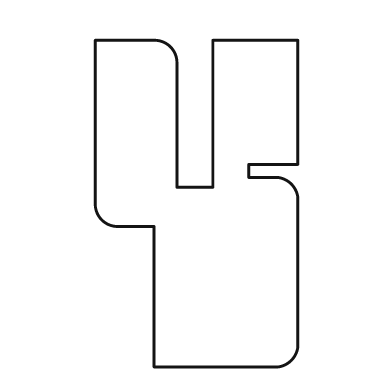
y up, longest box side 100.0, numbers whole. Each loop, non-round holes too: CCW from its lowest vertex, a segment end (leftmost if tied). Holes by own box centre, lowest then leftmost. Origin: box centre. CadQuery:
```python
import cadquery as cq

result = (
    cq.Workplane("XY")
    .moveTo(-13.0, -50.0)
    .lineTo(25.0, -50.0)
    .threePointArc((29.0, -48.0), (31.0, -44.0))
    .lineTo(31.0, 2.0)
    .threePointArc((29.0, 6.0), (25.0, 8.0))
    .lineTo(16.0, 8.0)
    .lineTo(16.0, 12.0)
    .lineTo(31.0, 12.0)
    .lineTo(31.0, 50.0)
    .lineTo(5.0, 50.0)
    .lineTo(5.0, 5.0)
    .lineTo(-6.0, 5.0)
    .lineTo(-6.0, 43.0)
    .threePointArc((-8.0, 48.0), (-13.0, 50.0))
    .lineTo(-31.0, 50.0)
    .lineTo(-31.0, 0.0)
    .threePointArc((-29.0, -5.0), (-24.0, -7.0))
    .lineTo(-13.0, -7.0)
    .close()
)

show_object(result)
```